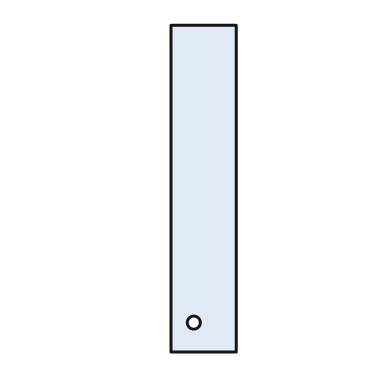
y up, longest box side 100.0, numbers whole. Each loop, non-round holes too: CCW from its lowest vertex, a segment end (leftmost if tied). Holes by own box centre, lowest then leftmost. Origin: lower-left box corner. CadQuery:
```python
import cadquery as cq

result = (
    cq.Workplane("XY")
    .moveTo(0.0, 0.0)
    .lineTo(20.0, 0.0)
    .lineTo(20.0, 100.0)
    .lineTo(0.0, 100.0)
    .close()
    .moveTo(7.0, 9.0)
    .circle(2.0)
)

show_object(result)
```